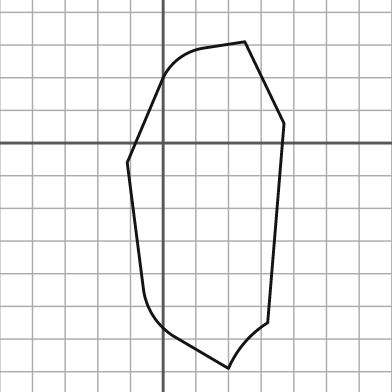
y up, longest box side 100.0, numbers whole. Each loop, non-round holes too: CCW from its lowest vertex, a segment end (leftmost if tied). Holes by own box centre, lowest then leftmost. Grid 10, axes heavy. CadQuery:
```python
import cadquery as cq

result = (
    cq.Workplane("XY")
    .moveTo(20.0, -69.0)
    .threePointArc((25.0, -61.0), (32.0, -55.0))
    .lineTo(37.0, 6.0)
    .lineTo(25.0, 31.0)
    .lineTo(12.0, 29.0)
    .threePointArc((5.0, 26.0), (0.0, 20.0))
    .lineTo(-11.0, -6.0)
    .lineTo(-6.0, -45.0)
    .threePointArc((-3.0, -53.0), (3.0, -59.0))
    .close()
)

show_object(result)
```